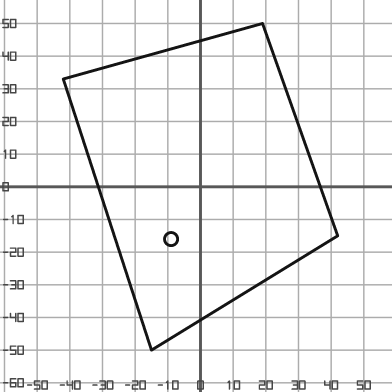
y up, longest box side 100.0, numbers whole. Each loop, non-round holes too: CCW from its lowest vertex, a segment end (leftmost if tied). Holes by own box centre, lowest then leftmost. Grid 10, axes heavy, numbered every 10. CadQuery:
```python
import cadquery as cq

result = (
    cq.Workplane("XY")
    .moveTo(-15.0, -50.0)
    .lineTo(42.0, -15.0)
    .lineTo(19.0, 50.0)
    .lineTo(-42.0, 33.0)
    .close()
    .moveTo(-9.0, -16.0)
    .circle(2.0)
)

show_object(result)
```